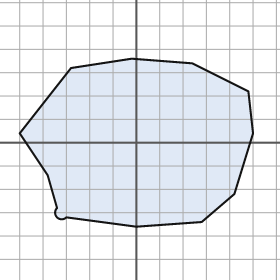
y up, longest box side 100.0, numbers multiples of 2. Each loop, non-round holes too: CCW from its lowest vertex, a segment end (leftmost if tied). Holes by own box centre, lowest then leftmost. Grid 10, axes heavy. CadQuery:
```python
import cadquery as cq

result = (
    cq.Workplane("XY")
    .moveTo(0.0, -36.0)
    .lineTo(28.0, -34.0)
    .lineTo(42.0, -22.0)
    .lineTo(50.0, 4.0)
    .lineTo(48.0, 22.0)
    .lineTo(24.0, 34.0)
    .lineTo(-2.0, 36.0)
    .lineTo(-28.0, 32.0)
    .lineTo(-50.0, 4.0)
    .lineTo(-38.0, -14.0)
    .lineTo(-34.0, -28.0)
    .threePointArc((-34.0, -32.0), (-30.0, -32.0))
    .close()
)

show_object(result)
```